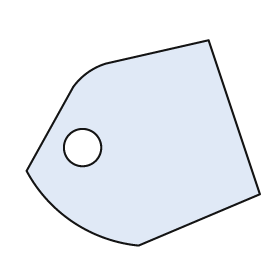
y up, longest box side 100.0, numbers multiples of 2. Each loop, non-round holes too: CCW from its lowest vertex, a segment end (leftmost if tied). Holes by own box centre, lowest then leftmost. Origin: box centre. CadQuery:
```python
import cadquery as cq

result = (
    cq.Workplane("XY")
    .moveTo(-2.0, -44.0)
    .lineTo(50.0, -22.0)
    .lineTo(28.0, 44.0)
    .lineTo(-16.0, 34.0)
    .threePointArc((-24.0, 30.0), (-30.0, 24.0))
    .lineTo(-50.0, -12.0)
    .threePointArc((-30.0, -34.0), (-2.0, -44.0))
    .close()
    .moveTo(-26.0, -2.0)
    .circle(8.0)
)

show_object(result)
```